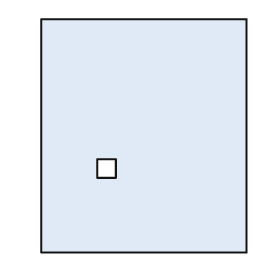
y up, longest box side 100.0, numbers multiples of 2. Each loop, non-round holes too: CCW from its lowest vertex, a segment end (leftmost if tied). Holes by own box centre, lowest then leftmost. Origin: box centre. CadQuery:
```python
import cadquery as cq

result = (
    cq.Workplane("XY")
    .moveTo(-44.0, -50.0)
    .lineTo(44.0, -50.0)
    .lineTo(44.0, 50.0)
    .lineTo(-44.0, 50.0)
    .close()
    .moveTo(-20.0, -18.0)
    .lineTo(-12.0, -18.0)
    .lineTo(-12.0, -10.0)
    .lineTo(-20.0, -10.0)
    .close()
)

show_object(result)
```